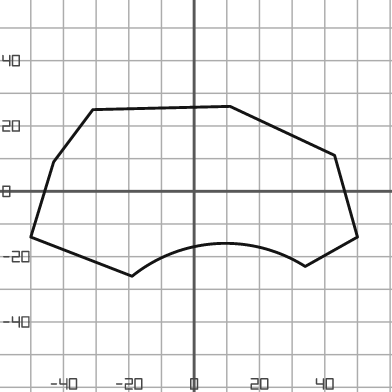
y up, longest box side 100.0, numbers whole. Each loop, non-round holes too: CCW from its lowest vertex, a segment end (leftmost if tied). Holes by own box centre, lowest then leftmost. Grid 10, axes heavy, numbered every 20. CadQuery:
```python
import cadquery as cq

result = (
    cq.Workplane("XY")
    .moveTo(-19.0, -26.0)
    .threePointArc((7.0, -16.0), (34.0, -23.0))
    .lineTo(50.0, -14.0)
    .lineTo(43.0, 11.0)
    .lineTo(11.0, 26.0)
    .lineTo(-31.0, 25.0)
    .lineTo(-43.0, 9.0)
    .lineTo(-50.0, -14.0)
    .close()
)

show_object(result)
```